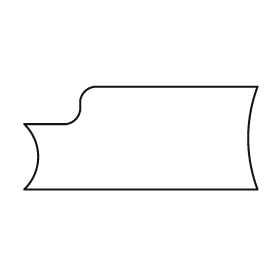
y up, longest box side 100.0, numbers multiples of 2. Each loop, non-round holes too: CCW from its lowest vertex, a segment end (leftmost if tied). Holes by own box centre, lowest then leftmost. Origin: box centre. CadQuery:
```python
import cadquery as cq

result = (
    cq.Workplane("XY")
    .moveTo(-50.0, -22.0)
    .lineTo(50.0, -22.0)
    .threePointArc((46.0, 0.0), (50.0, 22.0))
    .lineTo(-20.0, 22.0)
    .threePointArc((-24.0, 20.0), (-26.0, 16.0))
    .lineTo(-26.0, 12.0)
    .threePointArc((-28.0, 8.0), (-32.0, 6.0))
    .lineTo(-50.0, 6.0)
    .threePointArc((-44.0, -8.0), (-50.0, -22.0))
    .close()
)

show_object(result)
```